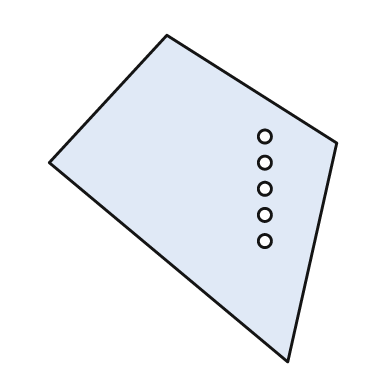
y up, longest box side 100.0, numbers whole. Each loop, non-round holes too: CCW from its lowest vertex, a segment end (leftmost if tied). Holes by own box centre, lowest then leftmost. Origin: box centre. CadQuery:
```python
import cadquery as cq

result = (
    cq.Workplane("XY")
    .moveTo(29.0, -50.0)
    .lineTo(44.0, 17.0)
    .lineTo(-8.0, 50.0)
    .lineTo(-44.0, 11.0)
    .close()
    .moveTo(22.0, -13.0)
    .circle(2.0)
    .moveTo(22.0, -5.0)
    .circle(2.0)
    .moveTo(22.0, 3.0)
    .circle(2.0)
    .moveTo(22.0, 11.0)
    .circle(2.0)
    .moveTo(22.0, 19.0)
    .circle(2.0)
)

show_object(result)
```